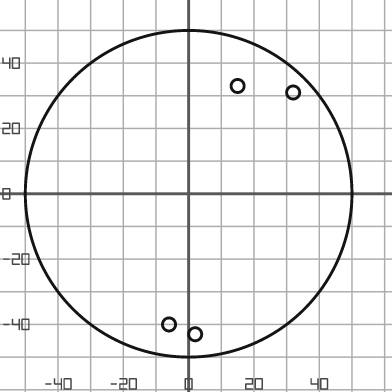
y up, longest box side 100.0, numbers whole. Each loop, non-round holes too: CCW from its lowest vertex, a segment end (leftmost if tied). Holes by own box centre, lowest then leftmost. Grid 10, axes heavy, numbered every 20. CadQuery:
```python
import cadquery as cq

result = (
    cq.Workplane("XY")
    .moveTo(0.0, 0.0)
    .circle(50.0)
    .moveTo(2.0, -43.0)
    .circle(2.0)
    .moveTo(-6.0, -40.0)
    .circle(2.0)
    .moveTo(32.0, 31.0)
    .circle(2.0)
    .moveTo(15.0, 33.0)
    .circle(2.0)
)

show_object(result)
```